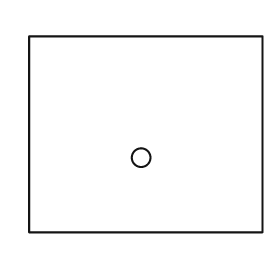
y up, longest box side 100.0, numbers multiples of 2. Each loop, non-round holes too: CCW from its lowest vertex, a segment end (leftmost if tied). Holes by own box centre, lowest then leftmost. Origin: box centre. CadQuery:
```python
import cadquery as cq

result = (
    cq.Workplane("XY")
    .moveTo(-50.0, -42.0)
    .lineTo(50.0, -42.0)
    .lineTo(50.0, 42.0)
    .lineTo(-50.0, 42.0)
    .close()
    .moveTo(-2.0, -10.0)
    .circle(4.0)
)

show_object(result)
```